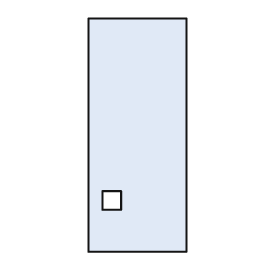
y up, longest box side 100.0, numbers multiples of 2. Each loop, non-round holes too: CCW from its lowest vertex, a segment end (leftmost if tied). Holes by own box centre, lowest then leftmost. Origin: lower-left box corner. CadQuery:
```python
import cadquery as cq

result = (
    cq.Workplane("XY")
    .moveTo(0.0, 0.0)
    .lineTo(42.0, 0.0)
    .lineTo(42.0, 100.0)
    .lineTo(0.0, 100.0)
    .close()
    .moveTo(6.0, 18.0)
    .lineTo(14.0, 18.0)
    .lineTo(14.0, 26.0)
    .lineTo(6.0, 26.0)
    .close()
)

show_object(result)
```